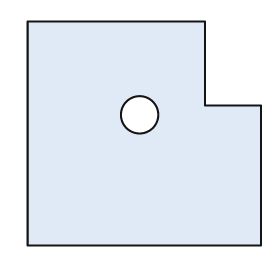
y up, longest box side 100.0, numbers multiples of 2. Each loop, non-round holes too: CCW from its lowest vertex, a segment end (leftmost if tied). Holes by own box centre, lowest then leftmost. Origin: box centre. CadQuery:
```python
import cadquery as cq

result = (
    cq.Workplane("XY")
    .moveTo(-50.0, -48.0)
    .lineTo(50.0, -48.0)
    .lineTo(50.0, 12.0)
    .lineTo(26.0, 12.0)
    .lineTo(26.0, 48.0)
    .lineTo(-50.0, 48.0)
    .close()
    .moveTo(-2.0, 8.0)
    .circle(8.0)
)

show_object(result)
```